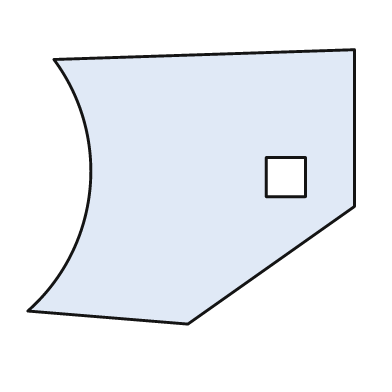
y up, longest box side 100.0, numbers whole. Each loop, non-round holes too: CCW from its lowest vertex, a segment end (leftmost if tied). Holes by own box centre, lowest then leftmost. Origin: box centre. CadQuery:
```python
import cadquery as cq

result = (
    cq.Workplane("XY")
    .moveTo(-1.0, -42.0)
    .lineTo(50.0, -6.0)
    .lineTo(50.0, 42.0)
    .lineTo(-42.0, 39.0)
    .threePointArc((-31.0, -1.0), (-50.0, -38.0))
    .close()
    .moveTo(23.0, -3.0)
    .lineTo(35.0, -3.0)
    .lineTo(35.0, 9.0)
    .lineTo(23.0, 9.0)
    .close()
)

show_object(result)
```